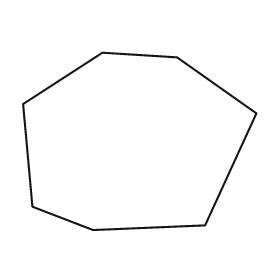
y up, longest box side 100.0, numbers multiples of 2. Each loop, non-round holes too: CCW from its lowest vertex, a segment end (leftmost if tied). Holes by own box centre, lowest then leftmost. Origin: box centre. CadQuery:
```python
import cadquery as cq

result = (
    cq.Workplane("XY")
    .moveTo(-20.0, -38.0)
    .lineTo(28.0, -36.0)
    .lineTo(50.0, 12.0)
    .lineTo(16.0, 36.0)
    .lineTo(-16.0, 38.0)
    .lineTo(-50.0, 16.0)
    .lineTo(-46.0, -28.0)
    .close()
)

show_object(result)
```